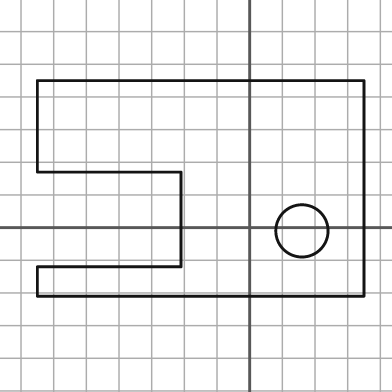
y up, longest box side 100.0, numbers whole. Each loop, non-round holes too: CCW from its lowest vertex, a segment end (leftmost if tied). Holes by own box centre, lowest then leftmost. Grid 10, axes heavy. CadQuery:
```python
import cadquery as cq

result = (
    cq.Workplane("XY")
    .moveTo(-65.0, -21.0)
    .lineTo(35.0, -21.0)
    .lineTo(35.0, 45.0)
    .lineTo(-65.0, 45.0)
    .lineTo(-65.0, 17.0)
    .lineTo(-21.0, 17.0)
    .lineTo(-21.0, -12.0)
    .lineTo(-65.0, -12.0)
    .close()
    .moveTo(16.0, -1.0)
    .circle(8.0)
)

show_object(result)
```